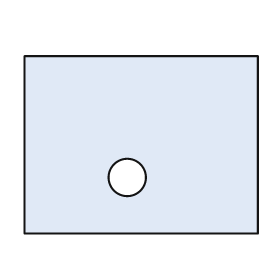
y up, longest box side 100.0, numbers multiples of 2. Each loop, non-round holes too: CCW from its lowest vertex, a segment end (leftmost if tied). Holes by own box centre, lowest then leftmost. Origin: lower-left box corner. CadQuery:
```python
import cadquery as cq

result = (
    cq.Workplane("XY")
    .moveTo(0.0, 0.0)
    .lineTo(100.0, 0.0)
    .lineTo(100.0, 76.0)
    .lineTo(0.0, 76.0)
    .close()
    .moveTo(44.0, 24.0)
    .circle(8.0)
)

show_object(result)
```